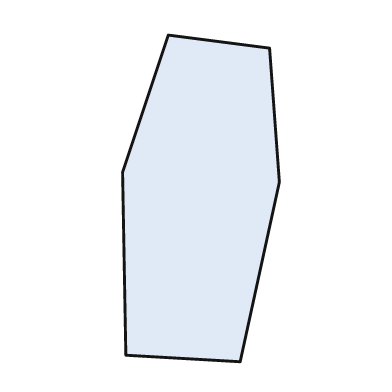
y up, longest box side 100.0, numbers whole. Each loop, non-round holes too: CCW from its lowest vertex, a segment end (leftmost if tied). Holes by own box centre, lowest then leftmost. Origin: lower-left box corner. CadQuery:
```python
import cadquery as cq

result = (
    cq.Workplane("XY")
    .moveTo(36.0, 0.0)
    .lineTo(48.0, 55.0)
    .lineTo(45.0, 96.0)
    .lineTo(14.0, 100.0)
    .lineTo(0.0, 58.0)
    .lineTo(1.0, 2.0)
    .close()
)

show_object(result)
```